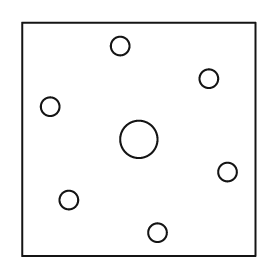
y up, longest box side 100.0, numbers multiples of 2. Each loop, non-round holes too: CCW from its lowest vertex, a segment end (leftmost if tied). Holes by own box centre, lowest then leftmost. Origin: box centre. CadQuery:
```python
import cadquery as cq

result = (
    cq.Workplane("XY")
    .moveTo(-50.0, -50.0)
    .lineTo(50.0, -50.0)
    .lineTo(50.0, 50.0)
    .lineTo(-50.0, 50.0)
    .close()
    .moveTo(8.0, -40.0)
    .circle(4.0)
    .moveTo(-30.0, -26.0)
    .circle(4.0)
    .moveTo(38.0, -14.0)
    .circle(4.0)
    .moveTo(0.0, 0.0)
    .circle(8.0)
    .moveTo(-38.0, 14.0)
    .circle(4.0)
    .moveTo(30.0, 26.0)
    .circle(4.0)
    .moveTo(-8.0, 40.0)
    .circle(4.0)
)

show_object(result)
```